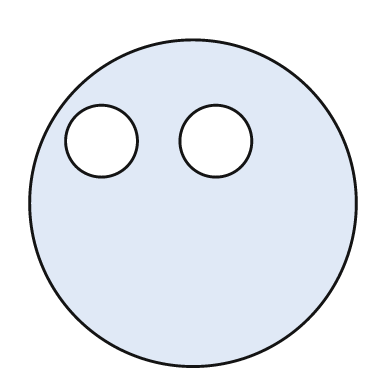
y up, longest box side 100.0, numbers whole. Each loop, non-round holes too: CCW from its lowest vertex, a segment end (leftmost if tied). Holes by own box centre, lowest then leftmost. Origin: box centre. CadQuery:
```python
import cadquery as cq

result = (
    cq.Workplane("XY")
    .moveTo(0.0, 0.0)
    .circle(50.0)
    .moveTo(-28.0, 19.0)
    .circle(11.0)
    .moveTo(7.0, 19.0)
    .circle(11.0)
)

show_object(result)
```